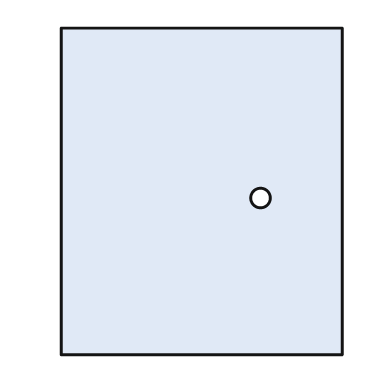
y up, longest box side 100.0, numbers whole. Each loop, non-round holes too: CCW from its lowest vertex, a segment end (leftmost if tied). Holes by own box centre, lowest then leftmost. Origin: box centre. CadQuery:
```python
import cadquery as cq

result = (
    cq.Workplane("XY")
    .moveTo(-43.0, -50.0)
    .lineTo(43.0, -50.0)
    .lineTo(43.0, 50.0)
    .lineTo(-43.0, 50.0)
    .close()
    .moveTo(18.0, -2.0)
    .circle(3.0)
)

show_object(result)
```